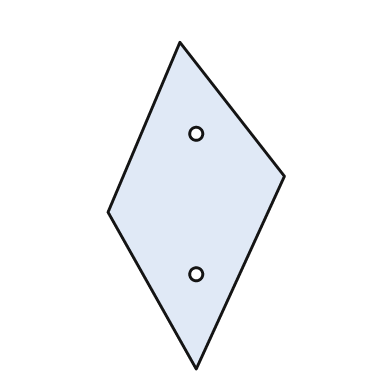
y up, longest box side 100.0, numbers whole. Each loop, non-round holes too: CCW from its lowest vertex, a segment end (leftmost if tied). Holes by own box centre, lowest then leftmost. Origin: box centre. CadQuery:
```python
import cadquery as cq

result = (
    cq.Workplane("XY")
    .moveTo(0.0, -50.0)
    .lineTo(27.0, 9.0)
    .lineTo(-5.0, 50.0)
    .lineTo(-27.0, -2.0)
    .close()
    .moveTo(0.0, -21.0)
    .circle(2.0)
    .moveTo(0.0, 22.0)
    .circle(2.0)
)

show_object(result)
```